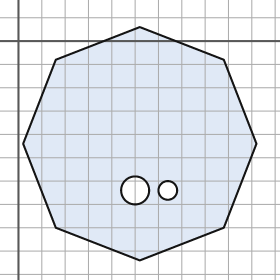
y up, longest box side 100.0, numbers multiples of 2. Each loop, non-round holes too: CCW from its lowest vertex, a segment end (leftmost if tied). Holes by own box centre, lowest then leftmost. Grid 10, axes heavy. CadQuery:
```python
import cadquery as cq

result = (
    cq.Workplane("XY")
    .moveTo(52.0, -94.0)
    .lineTo(88.0, -80.0)
    .lineTo(102.0, -44.0)
    .lineTo(88.0, -8.0)
    .lineTo(52.0, 6.0)
    .lineTo(16.0, -8.0)
    .lineTo(2.0, -44.0)
    .lineTo(16.0, -80.0)
    .close()
    .moveTo(50.0, -64.0)
    .circle(6.0)
    .moveTo(64.0, -64.0)
    .circle(4.0)
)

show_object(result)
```